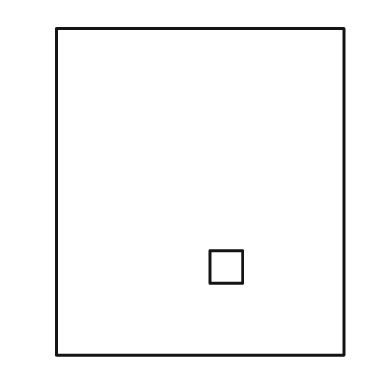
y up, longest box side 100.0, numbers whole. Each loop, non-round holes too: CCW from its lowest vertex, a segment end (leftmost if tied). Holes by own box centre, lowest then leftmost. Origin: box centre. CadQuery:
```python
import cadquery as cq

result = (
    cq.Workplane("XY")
    .moveTo(-44.0, -50.0)
    .lineTo(44.0, -50.0)
    .lineTo(44.0, 50.0)
    .lineTo(-44.0, 50.0)
    .close()
    .moveTo(3.0, -28.0)
    .lineTo(13.0, -28.0)
    .lineTo(13.0, -18.0)
    .lineTo(3.0, -18.0)
    .close()
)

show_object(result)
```